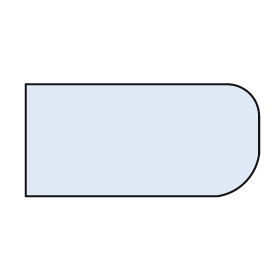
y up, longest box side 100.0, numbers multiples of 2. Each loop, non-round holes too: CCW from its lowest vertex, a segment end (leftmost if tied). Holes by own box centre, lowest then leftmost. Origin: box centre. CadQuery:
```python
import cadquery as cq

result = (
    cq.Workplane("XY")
    .moveTo(-50.0, -24.0)
    .lineTo(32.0, -24.0)
    .threePointArc((44.0, -18.0), (50.0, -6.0))
    .lineTo(50.0, 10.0)
    .threePointArc((46.0, 20.0), (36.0, 24.0))
    .lineTo(-50.0, 24.0)
    .close()
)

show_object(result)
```